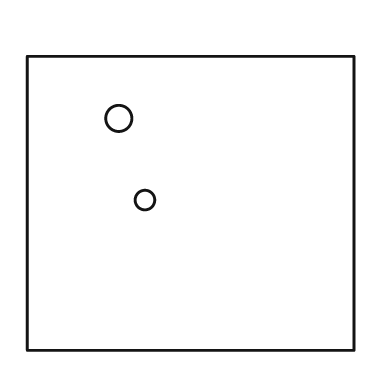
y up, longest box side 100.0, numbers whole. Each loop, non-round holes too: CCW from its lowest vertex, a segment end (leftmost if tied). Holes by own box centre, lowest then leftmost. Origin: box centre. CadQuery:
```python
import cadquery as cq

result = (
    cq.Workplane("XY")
    .moveTo(-50.0, -45.0)
    .lineTo(50.0, -45.0)
    .lineTo(50.0, 45.0)
    .lineTo(-50.0, 45.0)
    .close()
    .moveTo(-14.0, 1.0)
    .circle(3.0)
    .moveTo(-22.0, 26.0)
    .circle(4.0)
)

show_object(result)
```